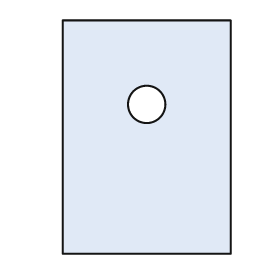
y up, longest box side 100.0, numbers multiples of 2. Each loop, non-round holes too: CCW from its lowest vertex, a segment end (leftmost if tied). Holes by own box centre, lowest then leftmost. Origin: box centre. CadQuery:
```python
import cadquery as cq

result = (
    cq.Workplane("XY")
    .moveTo(-36.0, -50.0)
    .lineTo(36.0, -50.0)
    .lineTo(36.0, 50.0)
    .lineTo(-36.0, 50.0)
    .close()
    .moveTo(0.0, 14.0)
    .circle(8.0)
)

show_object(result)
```